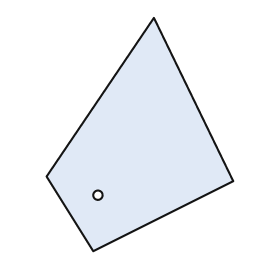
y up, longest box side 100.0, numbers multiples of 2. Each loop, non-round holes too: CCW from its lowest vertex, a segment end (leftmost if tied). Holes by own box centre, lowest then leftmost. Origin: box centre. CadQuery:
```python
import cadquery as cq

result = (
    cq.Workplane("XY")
    .moveTo(-20.0, -50.0)
    .lineTo(40.0, -20.0)
    .lineTo(6.0, 50.0)
    .lineTo(-40.0, -18.0)
    .close()
    .moveTo(-18.0, -26.0)
    .circle(2.0)
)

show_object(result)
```